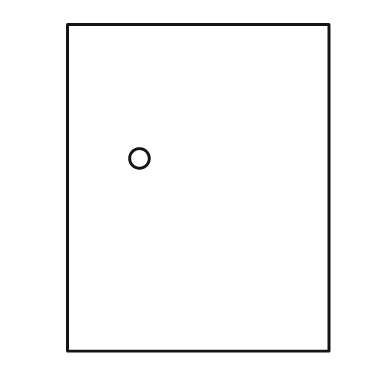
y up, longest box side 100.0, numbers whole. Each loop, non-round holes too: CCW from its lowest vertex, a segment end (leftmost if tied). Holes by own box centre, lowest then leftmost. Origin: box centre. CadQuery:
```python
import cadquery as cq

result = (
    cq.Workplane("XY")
    .moveTo(-40.0, -50.0)
    .lineTo(40.0, -50.0)
    .lineTo(40.0, 50.0)
    .lineTo(-40.0, 50.0)
    .close()
    .moveTo(-18.0, 9.0)
    .circle(3.0)
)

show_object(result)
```